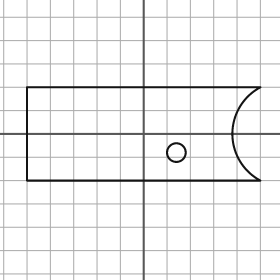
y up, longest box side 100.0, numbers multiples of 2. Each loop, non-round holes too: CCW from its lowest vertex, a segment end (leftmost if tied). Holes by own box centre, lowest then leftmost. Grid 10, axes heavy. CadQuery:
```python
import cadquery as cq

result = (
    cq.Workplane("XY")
    .moveTo(-50.0, -20.0)
    .lineTo(50.0, -20.0)
    .threePointArc((38.0, 0.0), (50.0, 20.0))
    .lineTo(-50.0, 20.0)
    .close()
    .moveTo(14.0, -8.0)
    .circle(4.0)
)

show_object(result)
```